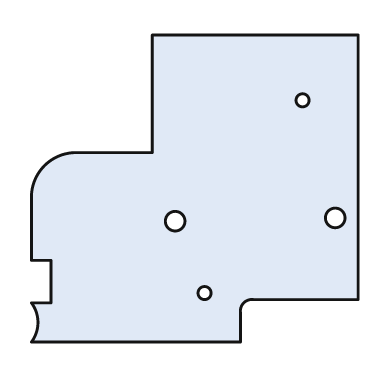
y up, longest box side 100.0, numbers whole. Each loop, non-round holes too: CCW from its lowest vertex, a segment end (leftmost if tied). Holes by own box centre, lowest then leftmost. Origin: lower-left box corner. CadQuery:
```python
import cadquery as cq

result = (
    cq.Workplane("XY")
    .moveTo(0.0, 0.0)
    .lineTo(64.0, 0.0)
    .lineTo(64.0, 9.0)
    .threePointArc((65.0, 12.0), (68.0, 13.0))
    .lineTo(100.0, 13.0)
    .lineTo(100.0, 94.0)
    .lineTo(37.0, 94.0)
    .lineTo(37.0, 58.0)
    .lineTo(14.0, 58.0)
    .threePointArc((4.0, 54.0), (0.0, 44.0))
    .lineTo(0.0, 25.0)
    .lineTo(6.0, 25.0)
    .lineTo(6.0, 12.0)
    .lineTo(0.0, 12.0)
    .threePointArc((2.0, 6.0), (0.0, 0.0))
    .close()
    .moveTo(53.0, 15.0)
    .circle(2.0)
    .moveTo(44.0, 37.0)
    .circle(3.0)
    .moveTo(93.0, 38.0)
    .circle(3.0)
    .moveTo(83.0, 74.0)
    .circle(2.0)
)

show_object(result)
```